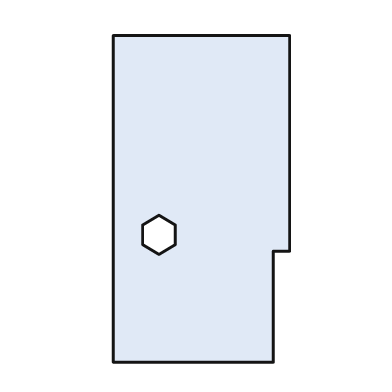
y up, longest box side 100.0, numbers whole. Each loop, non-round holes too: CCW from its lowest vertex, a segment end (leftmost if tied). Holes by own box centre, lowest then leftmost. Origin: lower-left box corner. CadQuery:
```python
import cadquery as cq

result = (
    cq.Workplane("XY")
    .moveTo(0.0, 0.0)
    .lineTo(49.0, 0.0)
    .lineTo(49.0, 34.0)
    .lineTo(54.0, 34.0)
    .lineTo(54.0, 100.0)
    .lineTo(0.0, 100.0)
    .close()
    .moveTo(14.0, 33.0)
    .lineTo(19.0, 36.0)
    .lineTo(19.0, 42.0)
    .lineTo(14.0, 45.0)
    .lineTo(9.0, 42.0)
    .lineTo(9.0, 36.0)
    .close()
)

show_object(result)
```